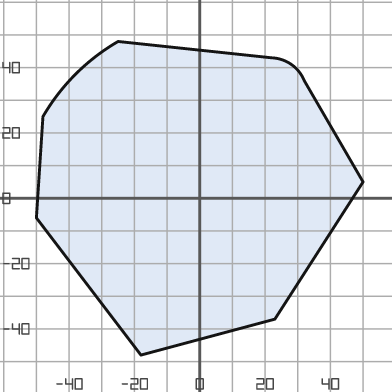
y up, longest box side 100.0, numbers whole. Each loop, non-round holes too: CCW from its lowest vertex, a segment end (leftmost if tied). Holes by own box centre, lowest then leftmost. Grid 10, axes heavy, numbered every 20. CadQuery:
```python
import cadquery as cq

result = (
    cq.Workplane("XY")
    .moveTo(-18.0, -48.0)
    .lineTo(23.0, -37.0)
    .lineTo(50.0, 5.0)
    .lineTo(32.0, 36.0)
    .threePointArc((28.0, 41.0), (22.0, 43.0))
    .lineTo(-25.0, 48.0)
    .threePointArc((-38.0, 38.0), (-48.0, 25.0))
    .lineTo(-50.0, -6.0)
    .close()
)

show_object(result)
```